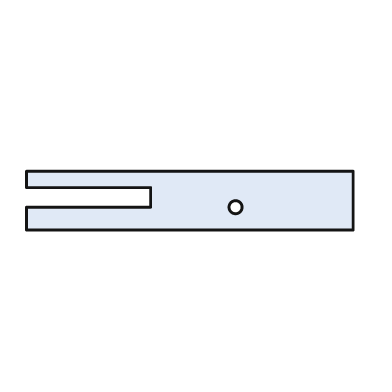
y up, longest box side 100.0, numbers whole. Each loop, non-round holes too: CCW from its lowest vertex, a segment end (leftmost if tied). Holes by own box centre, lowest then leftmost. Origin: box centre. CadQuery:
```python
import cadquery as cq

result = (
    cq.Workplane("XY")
    .moveTo(-50.0, -9.0)
    .lineTo(50.0, -9.0)
    .lineTo(50.0, 9.0)
    .lineTo(-50.0, 9.0)
    .lineTo(-50.0, 4.0)
    .lineTo(-12.0, 4.0)
    .lineTo(-12.0, -2.0)
    .lineTo(-50.0, -2.0)
    .close()
    .moveTo(14.0, -2.0)
    .circle(2.0)
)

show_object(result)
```